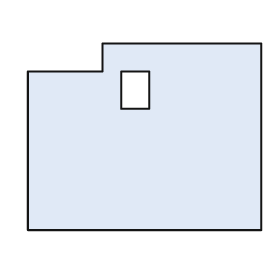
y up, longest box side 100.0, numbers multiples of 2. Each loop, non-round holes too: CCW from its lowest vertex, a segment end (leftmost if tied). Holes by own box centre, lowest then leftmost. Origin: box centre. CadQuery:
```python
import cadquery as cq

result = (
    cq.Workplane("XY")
    .moveTo(-50.0, -40.0)
    .lineTo(50.0, -40.0)
    .lineTo(50.0, 40.0)
    .lineTo(-18.0, 40.0)
    .lineTo(-18.0, 28.0)
    .lineTo(-50.0, 28.0)
    .close()
    .moveTo(-10.0, 12.0)
    .lineTo(2.0, 12.0)
    .lineTo(2.0, 28.0)
    .lineTo(-10.0, 28.0)
    .close()
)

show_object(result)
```